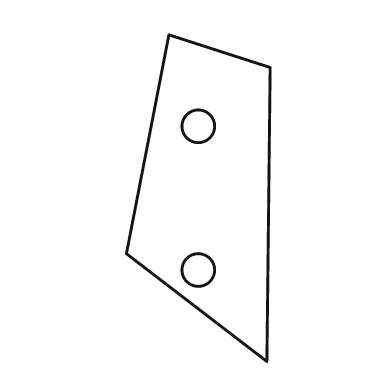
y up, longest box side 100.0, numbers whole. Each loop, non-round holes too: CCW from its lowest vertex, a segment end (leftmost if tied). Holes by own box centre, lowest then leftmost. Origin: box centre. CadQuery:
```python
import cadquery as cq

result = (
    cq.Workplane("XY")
    .moveTo(21.0, -50.0)
    .lineTo(22.0, 40.0)
    .lineTo(-9.0, 50.0)
    .lineTo(-22.0, -17.0)
    .close()
    .moveTo(0.0, -22.0)
    .circle(5.0)
    .moveTo(0.0, 22.0)
    .circle(5.0)
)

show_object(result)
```